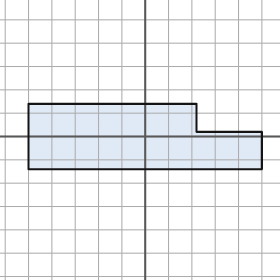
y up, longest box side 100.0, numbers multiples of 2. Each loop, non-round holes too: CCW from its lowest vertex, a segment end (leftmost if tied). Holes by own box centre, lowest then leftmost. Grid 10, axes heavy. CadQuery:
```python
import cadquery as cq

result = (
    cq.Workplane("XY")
    .moveTo(-50.0, -14.0)
    .lineTo(50.0, -14.0)
    .lineTo(50.0, 2.0)
    .lineTo(22.0, 2.0)
    .lineTo(22.0, 14.0)
    .lineTo(-50.0, 14.0)
    .close()
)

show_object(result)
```